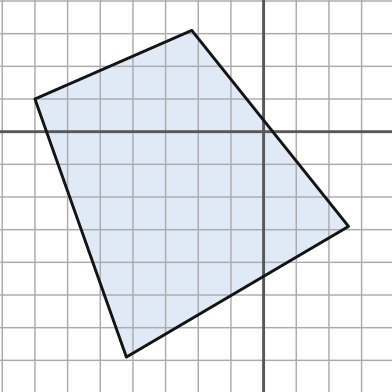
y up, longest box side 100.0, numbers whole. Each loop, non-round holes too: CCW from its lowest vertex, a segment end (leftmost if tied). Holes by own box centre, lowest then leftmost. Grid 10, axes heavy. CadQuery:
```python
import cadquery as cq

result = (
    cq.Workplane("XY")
    .moveTo(-42.0, -69.0)
    .lineTo(26.0, -29.0)
    .lineTo(-22.0, 31.0)
    .lineTo(-70.0, 10.0)
    .close()
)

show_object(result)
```